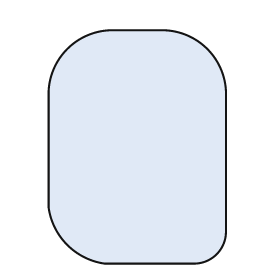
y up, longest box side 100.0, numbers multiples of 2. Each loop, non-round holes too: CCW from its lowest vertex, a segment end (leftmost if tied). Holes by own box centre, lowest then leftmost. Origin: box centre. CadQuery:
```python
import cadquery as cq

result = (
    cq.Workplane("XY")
    .moveTo(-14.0, -50.0)
    .lineTo(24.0, -50.0)
    .threePointArc((34.0, -46.0), (38.0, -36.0))
    .lineTo(38.0, 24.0)
    .threePointArc((30.0, 42.0), (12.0, 50.0))
    .lineTo(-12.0, 50.0)
    .threePointArc((-30.0, 42.0), (-38.0, 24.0))
    .lineTo(-38.0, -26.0)
    .threePointArc((-30.0, -42.0), (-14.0, -50.0))
    .close()
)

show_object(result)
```